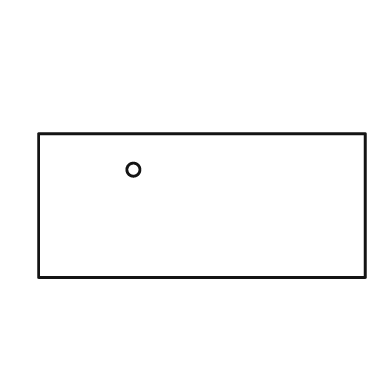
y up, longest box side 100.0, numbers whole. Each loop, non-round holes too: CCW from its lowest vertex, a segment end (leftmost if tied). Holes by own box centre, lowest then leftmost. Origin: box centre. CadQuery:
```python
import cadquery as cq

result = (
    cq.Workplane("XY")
    .moveTo(-50.0, -22.0)
    .lineTo(50.0, -22.0)
    .lineTo(50.0, 22.0)
    .lineTo(-50.0, 22.0)
    .close()
    .moveTo(-21.0, 11.0)
    .circle(2.0)
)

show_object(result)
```